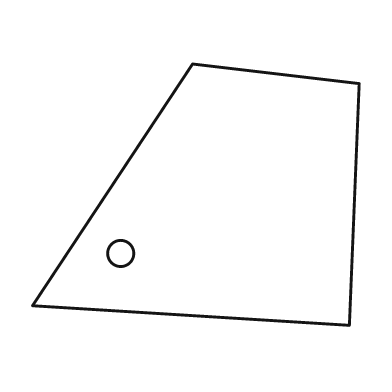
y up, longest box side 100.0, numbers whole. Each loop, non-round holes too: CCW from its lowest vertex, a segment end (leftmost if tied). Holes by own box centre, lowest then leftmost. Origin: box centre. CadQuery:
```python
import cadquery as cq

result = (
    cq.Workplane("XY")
    .moveTo(47.0, -40.0)
    .lineTo(50.0, 34.0)
    .lineTo(-1.0, 40.0)
    .lineTo(-50.0, -34.0)
    .close()
    .moveTo(-23.0, -18.0)
    .circle(4.0)
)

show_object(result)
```